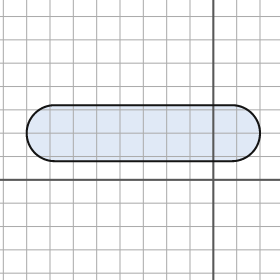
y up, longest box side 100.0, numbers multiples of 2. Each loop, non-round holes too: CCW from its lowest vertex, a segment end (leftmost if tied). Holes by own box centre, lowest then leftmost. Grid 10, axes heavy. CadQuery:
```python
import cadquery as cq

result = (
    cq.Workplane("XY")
    .moveTo(-68.0, 8.0)
    .lineTo(8.0, 8.0)
    .threePointArc((20.0, 20.0), (8.0, 32.0))
    .lineTo(-68.0, 32.0)
    .threePointArc((-80.0, 20.0), (-68.0, 8.0))
    .close()
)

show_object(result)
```